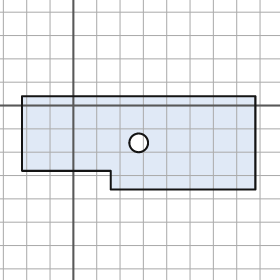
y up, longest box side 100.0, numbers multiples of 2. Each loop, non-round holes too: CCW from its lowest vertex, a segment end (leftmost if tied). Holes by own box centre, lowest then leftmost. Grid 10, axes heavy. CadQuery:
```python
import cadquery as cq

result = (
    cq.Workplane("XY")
    .moveTo(16.0, -36.0)
    .lineTo(78.0, -36.0)
    .lineTo(78.0, 4.0)
    .lineTo(-22.0, 4.0)
    .lineTo(-22.0, -28.0)
    .lineTo(16.0, -28.0)
    .close()
    .moveTo(28.0, -16.0)
    .circle(4.0)
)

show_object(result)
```